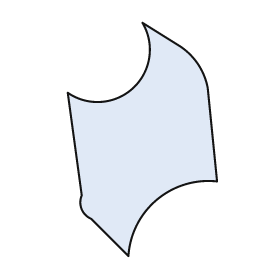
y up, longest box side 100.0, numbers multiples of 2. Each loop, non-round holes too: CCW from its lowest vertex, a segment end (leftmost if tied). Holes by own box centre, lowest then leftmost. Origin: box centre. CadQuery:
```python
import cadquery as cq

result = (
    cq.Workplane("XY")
    .moveTo(-6.0, -50.0)
    .threePointArc((6.0, -26.0), (32.0, -18.0))
    .lineTo(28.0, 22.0)
    .threePointArc((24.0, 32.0), (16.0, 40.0))
    .lineTo(0.0, 50.0)
    .threePointArc((-4.0, 22.0), (-32.0, 20.0))
    .lineTo(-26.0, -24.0)
    .threePointArc((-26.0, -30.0), (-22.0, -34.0))
    .close()
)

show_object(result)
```